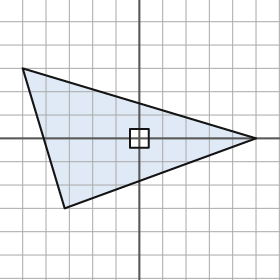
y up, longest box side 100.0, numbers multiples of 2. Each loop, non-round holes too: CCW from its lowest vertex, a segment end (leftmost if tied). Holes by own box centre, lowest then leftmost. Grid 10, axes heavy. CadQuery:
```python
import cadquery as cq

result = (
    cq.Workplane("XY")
    .moveTo(-32.0, -30.0)
    .lineTo(50.0, 0.0)
    .lineTo(-50.0, 30.0)
    .close()
    .moveTo(-4.0, -4.0)
    .lineTo(4.0, -4.0)
    .lineTo(4.0, 4.0)
    .lineTo(-4.0, 4.0)
    .close()
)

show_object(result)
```